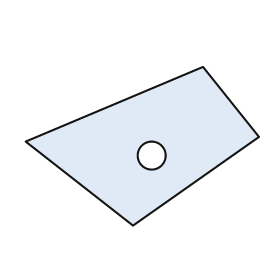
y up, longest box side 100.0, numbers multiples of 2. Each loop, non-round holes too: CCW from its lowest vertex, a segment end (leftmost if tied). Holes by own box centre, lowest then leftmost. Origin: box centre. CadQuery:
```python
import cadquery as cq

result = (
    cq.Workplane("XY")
    .moveTo(-4.0, -34.0)
    .lineTo(50.0, 4.0)
    .lineTo(26.0, 34.0)
    .lineTo(-50.0, 2.0)
    .close()
    .moveTo(4.0, -4.0)
    .circle(6.0)
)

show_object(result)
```